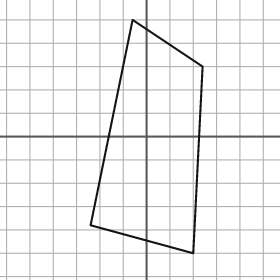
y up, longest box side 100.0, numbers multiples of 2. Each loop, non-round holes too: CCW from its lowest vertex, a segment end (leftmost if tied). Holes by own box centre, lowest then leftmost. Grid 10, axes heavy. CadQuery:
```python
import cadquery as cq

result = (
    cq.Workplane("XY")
    .moveTo(20.0, -50.0)
    .lineTo(24.0, 30.0)
    .lineTo(-6.0, 50.0)
    .lineTo(-24.0, -38.0)
    .close()
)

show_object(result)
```